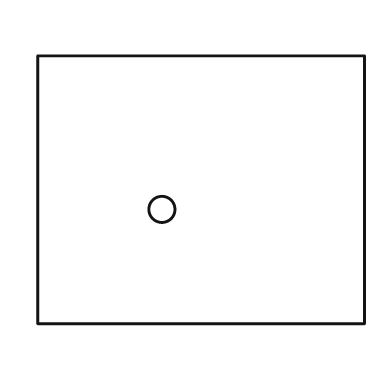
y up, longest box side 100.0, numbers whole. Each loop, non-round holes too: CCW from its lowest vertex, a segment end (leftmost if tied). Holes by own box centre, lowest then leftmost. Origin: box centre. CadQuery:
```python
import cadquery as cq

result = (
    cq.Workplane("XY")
    .moveTo(-50.0, -41.0)
    .lineTo(50.0, -41.0)
    .lineTo(50.0, 41.0)
    .lineTo(-50.0, 41.0)
    .close()
    .moveTo(-12.0, -6.0)
    .circle(4.0)
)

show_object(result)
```